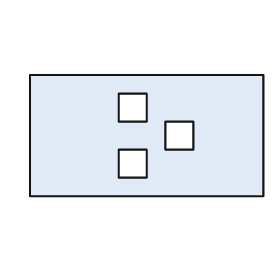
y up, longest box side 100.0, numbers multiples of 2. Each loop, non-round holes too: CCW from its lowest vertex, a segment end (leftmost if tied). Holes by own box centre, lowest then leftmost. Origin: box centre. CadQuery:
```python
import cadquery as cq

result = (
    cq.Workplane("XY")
    .moveTo(-50.0, -26.0)
    .lineTo(50.0, -26.0)
    .lineTo(50.0, 26.0)
    .lineTo(-50.0, 26.0)
    .close()
    .moveTo(-12.0, -18.0)
    .lineTo(0.0, -18.0)
    .lineTo(0.0, -6.0)
    .lineTo(-12.0, -6.0)
    .close()
    .moveTo(8.0, -6.0)
    .lineTo(20.0, -6.0)
    .lineTo(20.0, 6.0)
    .lineTo(8.0, 6.0)
    .close()
    .moveTo(-12.0, 6.0)
    .lineTo(0.0, 6.0)
    .lineTo(0.0, 18.0)
    .lineTo(-12.0, 18.0)
    .close()
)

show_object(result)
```